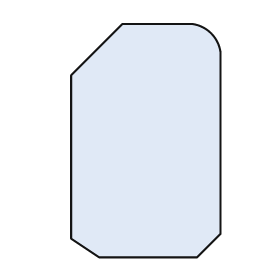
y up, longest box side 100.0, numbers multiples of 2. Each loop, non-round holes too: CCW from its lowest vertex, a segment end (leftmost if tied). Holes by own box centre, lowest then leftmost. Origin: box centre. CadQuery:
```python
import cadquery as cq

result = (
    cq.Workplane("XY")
    .moveTo(-20.0, -50.0)
    .lineTo(22.0, -50.0)
    .lineTo(32.0, -40.0)
    .lineTo(32.0, 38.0)
    .threePointArc((28.0, 46.0), (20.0, 50.0))
    .lineTo(-10.0, 50.0)
    .lineTo(-32.0, 28.0)
    .lineTo(-32.0, -42.0)
    .close()
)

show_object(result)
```